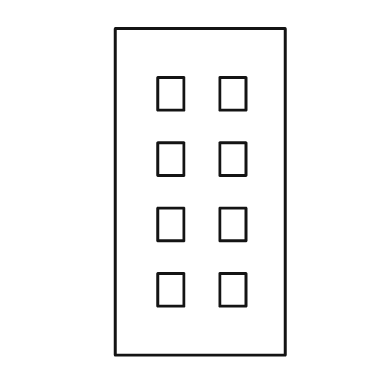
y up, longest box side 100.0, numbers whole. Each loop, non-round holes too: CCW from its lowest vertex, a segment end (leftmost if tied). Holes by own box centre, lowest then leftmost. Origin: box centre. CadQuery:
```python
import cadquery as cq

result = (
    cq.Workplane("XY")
    .moveTo(-26.0, -50.0)
    .lineTo(26.0, -50.0)
    .lineTo(26.0, 50.0)
    .lineTo(-26.0, 50.0)
    .close()
    .moveTo(-13.0, -35.0)
    .lineTo(-5.0, -35.0)
    .lineTo(-5.0, -25.0)
    .lineTo(-13.0, -25.0)
    .close()
    .moveTo(6.0, -35.0)
    .lineTo(14.0, -35.0)
    .lineTo(14.0, -25.0)
    .lineTo(6.0, -25.0)
    .close()
    .moveTo(-13.0, -15.0)
    .lineTo(-5.0, -15.0)
    .lineTo(-5.0, -5.0)
    .lineTo(-13.0, -5.0)
    .close()
    .moveTo(6.0, -15.0)
    .lineTo(14.0, -15.0)
    .lineTo(14.0, -5.0)
    .lineTo(6.0, -5.0)
    .close()
    .moveTo(-13.0, 5.0)
    .lineTo(-5.0, 5.0)
    .lineTo(-5.0, 15.0)
    .lineTo(-13.0, 15.0)
    .close()
    .moveTo(6.0, 5.0)
    .lineTo(14.0, 5.0)
    .lineTo(14.0, 15.0)
    .lineTo(6.0, 15.0)
    .close()
    .moveTo(-13.0, 25.0)
    .lineTo(-5.0, 25.0)
    .lineTo(-5.0, 35.0)
    .lineTo(-13.0, 35.0)
    .close()
    .moveTo(6.0, 25.0)
    .lineTo(14.0, 25.0)
    .lineTo(14.0, 35.0)
    .lineTo(6.0, 35.0)
    .close()
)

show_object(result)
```